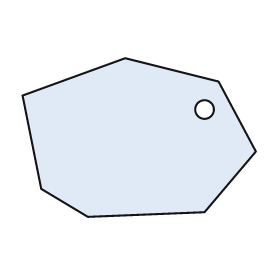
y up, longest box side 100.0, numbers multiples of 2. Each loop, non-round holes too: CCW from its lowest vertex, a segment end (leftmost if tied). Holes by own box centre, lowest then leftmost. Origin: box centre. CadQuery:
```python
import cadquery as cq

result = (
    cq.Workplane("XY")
    .moveTo(-22.0, -34.0)
    .lineTo(28.0, -32.0)
    .lineTo(50.0, -6.0)
    .lineTo(34.0, 24.0)
    .lineTo(-6.0, 34.0)
    .lineTo(-50.0, 18.0)
    .lineTo(-42.0, -22.0)
    .close()
    .moveTo(28.0, 12.0)
    .circle(4.0)
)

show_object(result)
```